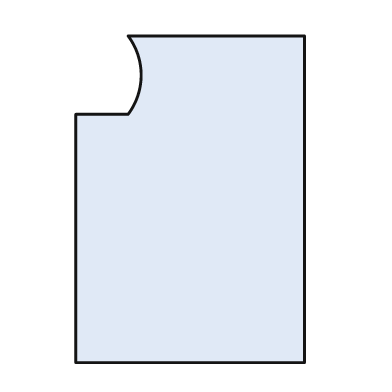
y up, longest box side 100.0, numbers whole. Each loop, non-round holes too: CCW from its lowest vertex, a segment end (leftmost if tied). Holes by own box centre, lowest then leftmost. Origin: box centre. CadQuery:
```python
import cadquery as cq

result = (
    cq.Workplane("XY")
    .moveTo(-35.0, -50.0)
    .lineTo(35.0, -50.0)
    .lineTo(35.0, 50.0)
    .lineTo(-19.0, 50.0)
    .threePointArc((-15.0, 38.0), (-19.0, 26.0))
    .lineTo(-35.0, 26.0)
    .close()
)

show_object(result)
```